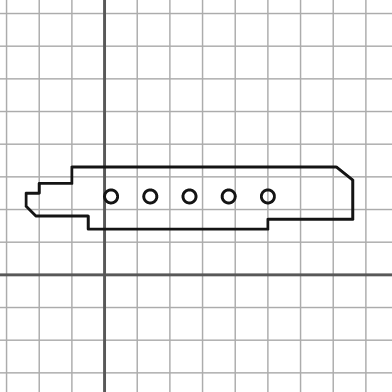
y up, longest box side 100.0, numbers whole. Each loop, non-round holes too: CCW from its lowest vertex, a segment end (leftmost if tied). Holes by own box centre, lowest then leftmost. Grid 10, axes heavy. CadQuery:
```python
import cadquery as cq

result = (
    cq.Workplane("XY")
    .moveTo(-5.0, 14.0)
    .lineTo(50.0, 14.0)
    .lineTo(50.0, 17.0)
    .lineTo(76.0, 17.0)
    .lineTo(76.0, 29.0)
    .lineTo(71.0, 33.0)
    .lineTo(-10.0, 33.0)
    .lineTo(-10.0, 28.0)
    .lineTo(-20.0, 28.0)
    .lineTo(-20.0, 25.0)
    .lineTo(-24.0, 25.0)
    .lineTo(-24.0, 21.0)
    .lineTo(-21.0, 18.0)
    .lineTo(-5.0, 18.0)
    .close()
    .moveTo(2.0, 24.0)
    .circle(2.0)
    .moveTo(14.0, 24.0)
    .circle(2.0)
    .moveTo(26.0, 24.0)
    .circle(2.0)
    .moveTo(38.0, 24.0)
    .circle(2.0)
    .moveTo(50.0, 24.0)
    .circle(2.0)
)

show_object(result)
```